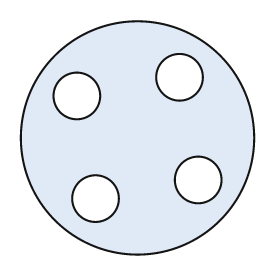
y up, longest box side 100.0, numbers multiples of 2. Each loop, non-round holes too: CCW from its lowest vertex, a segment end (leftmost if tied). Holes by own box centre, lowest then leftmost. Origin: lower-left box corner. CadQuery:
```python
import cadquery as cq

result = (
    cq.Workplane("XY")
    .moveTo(50.0, 50.0)
    .circle(50.0)
    .moveTo(32.0, 24.0)
    .circle(10.0)
    .moveTo(76.0, 32.0)
    .circle(10.0)
    .moveTo(24.0, 68.0)
    .circle(10.0)
    .moveTo(68.0, 76.0)
    .circle(10.0)
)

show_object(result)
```